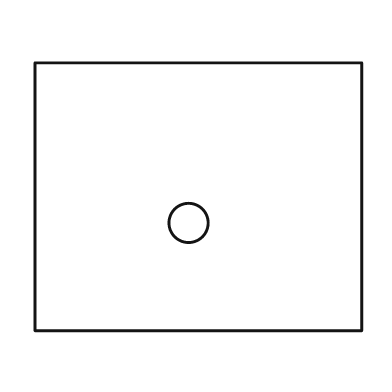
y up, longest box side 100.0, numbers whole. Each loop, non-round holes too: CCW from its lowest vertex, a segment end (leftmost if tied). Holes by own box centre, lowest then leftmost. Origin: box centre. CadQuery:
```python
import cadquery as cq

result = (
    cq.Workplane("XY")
    .moveTo(-50.0, -41.0)
    .lineTo(50.0, -41.0)
    .lineTo(50.0, 41.0)
    .lineTo(-50.0, 41.0)
    .close()
    .moveTo(-3.0, -8.0)
    .circle(6.0)
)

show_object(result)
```